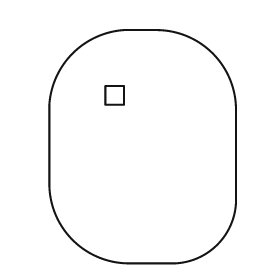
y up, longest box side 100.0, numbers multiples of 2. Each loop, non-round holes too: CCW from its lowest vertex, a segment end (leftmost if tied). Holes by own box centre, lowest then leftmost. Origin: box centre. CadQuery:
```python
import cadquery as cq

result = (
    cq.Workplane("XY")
    .moveTo(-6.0, -50.0)
    .lineTo(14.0, -50.0)
    .threePointArc((32.0, -42.0), (40.0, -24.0))
    .lineTo(40.0, 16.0)
    .threePointArc((30.0, 40.0), (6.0, 50.0))
    .lineTo(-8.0, 50.0)
    .threePointArc((-30.0, 40.0), (-40.0, 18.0))
    .lineTo(-40.0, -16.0)
    .threePointArc((-30.0, -40.0), (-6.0, -50.0))
    .close()
    .moveTo(-16.0, 18.0)
    .lineTo(-8.0, 18.0)
    .lineTo(-8.0, 26.0)
    .lineTo(-16.0, 26.0)
    .close()
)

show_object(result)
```